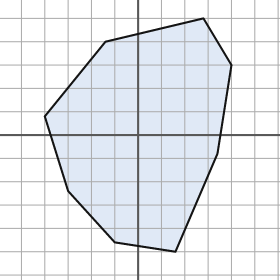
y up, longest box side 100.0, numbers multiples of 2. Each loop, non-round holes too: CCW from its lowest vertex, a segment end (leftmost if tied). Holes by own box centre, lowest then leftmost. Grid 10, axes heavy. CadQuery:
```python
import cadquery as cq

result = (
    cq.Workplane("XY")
    .moveTo(16.0, -50.0)
    .lineTo(34.0, -8.0)
    .lineTo(40.0, 30.0)
    .lineTo(28.0, 50.0)
    .lineTo(-14.0, 40.0)
    .lineTo(-40.0, 8.0)
    .lineTo(-30.0, -24.0)
    .lineTo(-10.0, -46.0)
    .close()
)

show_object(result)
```